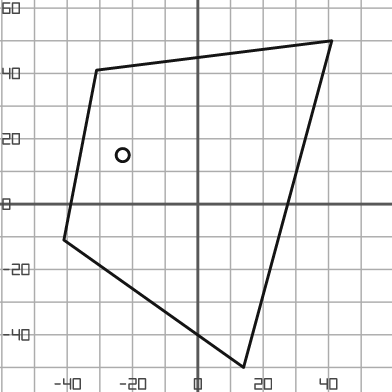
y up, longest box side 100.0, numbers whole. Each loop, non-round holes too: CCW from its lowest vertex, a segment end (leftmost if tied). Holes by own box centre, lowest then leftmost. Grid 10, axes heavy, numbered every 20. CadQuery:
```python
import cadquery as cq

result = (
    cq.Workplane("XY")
    .moveTo(14.0, -50.0)
    .lineTo(41.0, 50.0)
    .lineTo(-31.0, 41.0)
    .lineTo(-41.0, -11.0)
    .close()
    .moveTo(-23.0, 15.0)
    .circle(2.0)
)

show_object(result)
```